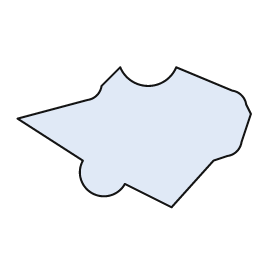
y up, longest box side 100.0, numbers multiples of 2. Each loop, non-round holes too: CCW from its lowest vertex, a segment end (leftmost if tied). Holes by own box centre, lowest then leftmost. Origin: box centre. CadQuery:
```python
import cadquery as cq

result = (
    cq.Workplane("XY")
    .moveTo(16.0, -30.0)
    .lineTo(34.0, -10.0)
    .lineTo(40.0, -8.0)
    .threePointArc((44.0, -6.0), (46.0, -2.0))
    .lineTo(50.0, 10.0)
    .lineTo(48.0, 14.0)
    .threePointArc((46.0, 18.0), (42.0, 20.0))
    .lineTo(18.0, 30.0)
    .threePointArc((6.0, 22.0), (-6.0, 30.0))
    .lineTo(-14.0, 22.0)
    .threePointArc((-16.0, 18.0), (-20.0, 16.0))
    .lineTo(-50.0, 8.0)
    .lineTo(-22.0, -10.0)
    .threePointArc((-18.0, -24.0), (-4.0, -20.0))
    .close()
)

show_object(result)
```